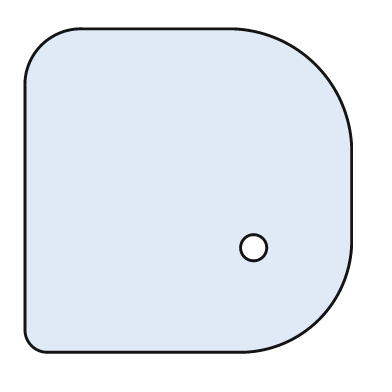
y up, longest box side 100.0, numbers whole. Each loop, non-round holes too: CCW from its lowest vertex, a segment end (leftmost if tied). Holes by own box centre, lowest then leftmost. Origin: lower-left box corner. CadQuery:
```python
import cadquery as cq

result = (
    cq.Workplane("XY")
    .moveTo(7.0, 0.0)
    .lineTo(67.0, 0.0)
    .threePointArc((90.0, 10.0), (100.0, 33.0))
    .lineTo(100.0, 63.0)
    .threePointArc((89.0, 88.0), (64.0, 99.0))
    .lineTo(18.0, 99.0)
    .threePointArc((5.0, 94.0), (0.0, 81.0))
    .lineTo(0.0, 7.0)
    .threePointArc((2.0, 2.0), (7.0, 0.0))
    .close()
    .moveTo(70.0, 32.0)
    .circle(4.0)
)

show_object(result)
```